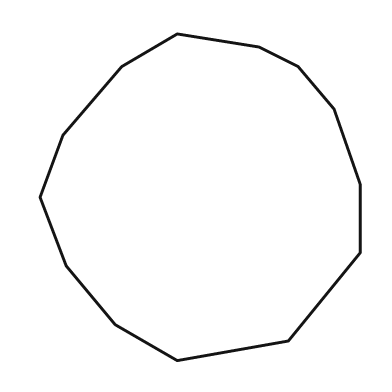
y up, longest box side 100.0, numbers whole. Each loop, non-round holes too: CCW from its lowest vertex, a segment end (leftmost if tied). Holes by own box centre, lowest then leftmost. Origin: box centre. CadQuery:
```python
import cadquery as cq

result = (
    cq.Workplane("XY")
    .moveTo(-7.0, -50.0)
    .lineTo(27.0, -44.0)
    .lineTo(49.0, -17.0)
    .lineTo(49.0, 4.0)
    .lineTo(41.0, 27.0)
    .lineTo(30.0, 40.0)
    .lineTo(18.0, 46.0)
    .lineTo(-7.0, 50.0)
    .lineTo(-24.0, 40.0)
    .lineTo(-42.0, 19.0)
    .lineTo(-49.0, 0.0)
    .lineTo(-41.0, -21.0)
    .lineTo(-26.0, -39.0)
    .close()
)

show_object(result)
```